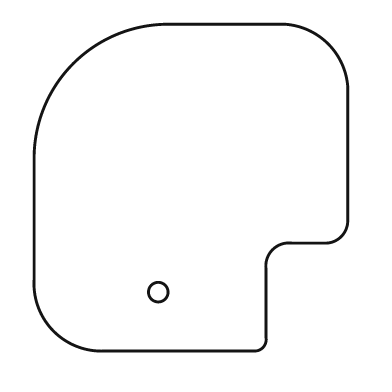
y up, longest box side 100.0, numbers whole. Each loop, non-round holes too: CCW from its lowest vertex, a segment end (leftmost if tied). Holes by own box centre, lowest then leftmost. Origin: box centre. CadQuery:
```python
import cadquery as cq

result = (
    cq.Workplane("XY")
    .moveTo(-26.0, -50.0)
    .lineTo(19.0, -50.0)
    .threePointArc((22.0, -49.0), (23.0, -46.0))
    .lineTo(23.0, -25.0)
    .threePointArc((25.0, -19.0), (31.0, -17.0))
    .lineTo(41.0, -17.0)
    .threePointArc((46.0, -15.0), (48.0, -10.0))
    .lineTo(48.0, 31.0)
    .threePointArc((42.0, 44.0), (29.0, 50.0))
    .lineTo(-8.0, 50.0)
    .threePointArc((-36.0, 38.0), (-48.0, 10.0))
    .lineTo(-48.0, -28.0)
    .threePointArc((-42.0, -44.0), (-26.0, -50.0))
    .close()
    .moveTo(-10.0, -32.0)
    .circle(3.0)
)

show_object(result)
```